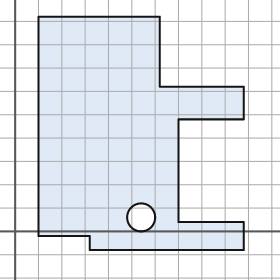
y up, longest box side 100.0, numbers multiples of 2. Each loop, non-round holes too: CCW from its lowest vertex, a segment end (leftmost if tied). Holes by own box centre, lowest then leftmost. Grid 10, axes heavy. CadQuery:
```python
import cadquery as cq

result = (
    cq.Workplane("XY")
    .moveTo(32.0, -8.0)
    .lineTo(98.0, -8.0)
    .lineTo(98.0, 4.0)
    .lineTo(70.0, 4.0)
    .lineTo(70.0, 48.0)
    .lineTo(98.0, 48.0)
    .lineTo(98.0, 62.0)
    .lineTo(62.0, 62.0)
    .lineTo(62.0, 92.0)
    .lineTo(10.0, 92.0)
    .lineTo(10.0, -2.0)
    .lineTo(32.0, -2.0)
    .close()
    .moveTo(54.0, 6.0)
    .circle(6.0)
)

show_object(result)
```